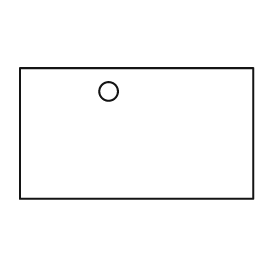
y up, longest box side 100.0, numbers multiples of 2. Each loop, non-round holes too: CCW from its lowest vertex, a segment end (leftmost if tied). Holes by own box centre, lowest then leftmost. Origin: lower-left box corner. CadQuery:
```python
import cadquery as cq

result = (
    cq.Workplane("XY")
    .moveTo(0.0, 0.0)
    .lineTo(100.0, 0.0)
    .lineTo(100.0, 56.0)
    .lineTo(0.0, 56.0)
    .close()
    .moveTo(38.0, 46.0)
    .circle(4.0)
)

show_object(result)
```